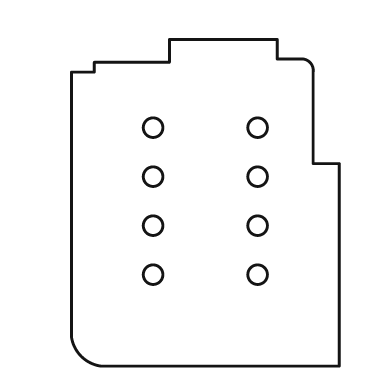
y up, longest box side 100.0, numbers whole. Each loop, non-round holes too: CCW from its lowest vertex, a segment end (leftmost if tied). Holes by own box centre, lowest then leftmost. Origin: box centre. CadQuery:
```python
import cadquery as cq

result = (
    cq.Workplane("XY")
    .moveTo(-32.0, -50.0)
    .lineTo(41.0, -50.0)
    .lineTo(41.0, 12.0)
    .lineTo(33.0, 12.0)
    .lineTo(33.0, 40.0)
    .threePointArc((32.0, 43.0), (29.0, 44.0))
    .lineTo(22.0, 44.0)
    .lineTo(22.0, 50.0)
    .lineTo(-11.0, 50.0)
    .lineTo(-11.0, 43.0)
    .lineTo(-34.0, 43.0)
    .lineTo(-34.0, 40.0)
    .lineTo(-41.0, 40.0)
    .lineTo(-41.0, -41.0)
    .threePointArc((-38.0, -47.0), (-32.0, -50.0))
    .close()
    .moveTo(-16.0, -22.0)
    .circle(3.0)
    .moveTo(16.0, -22.0)
    .circle(3.0)
    .moveTo(-16.0, -7.0)
    .circle(3.0)
    .moveTo(16.0, -7.0)
    .circle(3.0)
    .moveTo(-16.0, 8.0)
    .circle(3.0)
    .moveTo(16.0, 8.0)
    .circle(3.0)
    .moveTo(-16.0, 23.0)
    .circle(3.0)
    .moveTo(16.0, 23.0)
    .circle(3.0)
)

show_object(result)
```